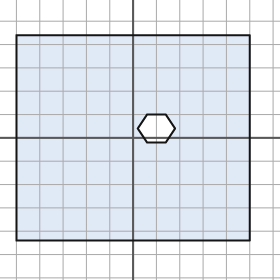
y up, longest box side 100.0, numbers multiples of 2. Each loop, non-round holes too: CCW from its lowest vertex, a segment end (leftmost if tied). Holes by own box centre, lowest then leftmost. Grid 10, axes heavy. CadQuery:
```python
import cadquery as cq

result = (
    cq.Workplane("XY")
    .moveTo(-50.0, -44.0)
    .lineTo(50.0, -44.0)
    .lineTo(50.0, 44.0)
    .lineTo(-50.0, 44.0)
    .close()
    .moveTo(6.0, -2.0)
    .lineTo(14.0, -2.0)
    .lineTo(18.0, 4.0)
    .lineTo(14.0, 10.0)
    .lineTo(6.0, 10.0)
    .lineTo(2.0, 4.0)
    .close()
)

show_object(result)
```